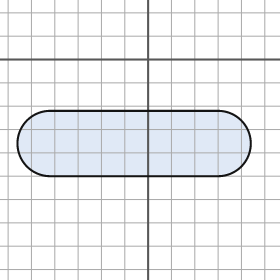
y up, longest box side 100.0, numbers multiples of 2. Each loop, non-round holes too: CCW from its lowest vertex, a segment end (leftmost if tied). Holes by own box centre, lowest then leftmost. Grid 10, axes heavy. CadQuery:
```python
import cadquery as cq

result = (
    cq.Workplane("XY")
    .moveTo(-42.0, -50.0)
    .lineTo(30.0, -50.0)
    .threePointArc((44.0, -36.0), (30.0, -22.0))
    .lineTo(-42.0, -22.0)
    .threePointArc((-56.0, -36.0), (-42.0, -50.0))
    .close()
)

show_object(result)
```